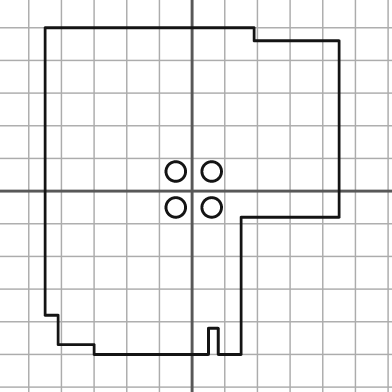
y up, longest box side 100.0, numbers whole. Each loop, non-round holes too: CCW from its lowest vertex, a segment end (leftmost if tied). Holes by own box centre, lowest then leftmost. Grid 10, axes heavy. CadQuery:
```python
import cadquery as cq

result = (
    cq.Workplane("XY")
    .moveTo(-30.0, -50.0)
    .lineTo(5.0, -50.0)
    .lineTo(5.0, -42.0)
    .lineTo(8.0, -42.0)
    .lineTo(8.0, -50.0)
    .lineTo(15.0, -50.0)
    .lineTo(15.0, -8.0)
    .lineTo(45.0, -8.0)
    .lineTo(45.0, 46.0)
    .lineTo(19.0, 46.0)
    .lineTo(19.0, 50.0)
    .lineTo(-45.0, 50.0)
    .lineTo(-45.0, -38.0)
    .lineTo(-41.0, -38.0)
    .lineTo(-41.0, -47.0)
    .lineTo(-30.0, -47.0)
    .close()
    .moveTo(-5.0, -5.0)
    .circle(3.0)
    .moveTo(6.0, -5.0)
    .circle(3.0)
    .moveTo(-5.0, 6.0)
    .circle(3.0)
    .moveTo(6.0, 6.0)
    .circle(3.0)
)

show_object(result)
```